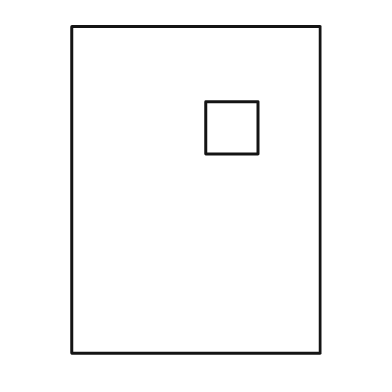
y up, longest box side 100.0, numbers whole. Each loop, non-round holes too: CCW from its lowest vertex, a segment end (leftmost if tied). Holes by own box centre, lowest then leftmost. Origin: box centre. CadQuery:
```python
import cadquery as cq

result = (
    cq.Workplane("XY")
    .moveTo(-38.0, -50.0)
    .lineTo(38.0, -50.0)
    .lineTo(38.0, 50.0)
    .lineTo(-38.0, 50.0)
    .close()
    .moveTo(3.0, 11.0)
    .lineTo(19.0, 11.0)
    .lineTo(19.0, 27.0)
    .lineTo(3.0, 27.0)
    .close()
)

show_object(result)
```